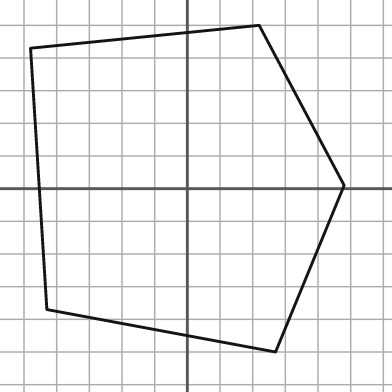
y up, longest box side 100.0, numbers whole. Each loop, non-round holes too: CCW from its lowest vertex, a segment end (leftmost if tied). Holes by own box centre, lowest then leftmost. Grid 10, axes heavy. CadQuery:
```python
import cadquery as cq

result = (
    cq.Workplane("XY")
    .moveTo(27.0, -50.0)
    .lineTo(48.0, 1.0)
    .lineTo(22.0, 50.0)
    .lineTo(-48.0, 43.0)
    .lineTo(-43.0, -37.0)
    .close()
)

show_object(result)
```